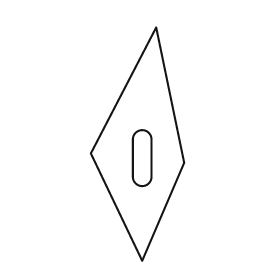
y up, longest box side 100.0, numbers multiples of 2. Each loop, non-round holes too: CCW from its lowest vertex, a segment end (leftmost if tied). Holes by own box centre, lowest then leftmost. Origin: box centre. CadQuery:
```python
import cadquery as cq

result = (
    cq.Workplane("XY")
    .moveTo(2.0, -50.0)
    .lineTo(20.0, -8.0)
    .lineTo(8.0, 50.0)
    .lineTo(-20.0, -4.0)
    .close()
    .moveTo(-2.0, -14.0)
    .threePointArc((2.0, -18.0), (6.0, -14.0))
    .lineTo(6.0, 2.0)
    .threePointArc((2.0, 6.0), (-2.0, 2.0))
    .close()
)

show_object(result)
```